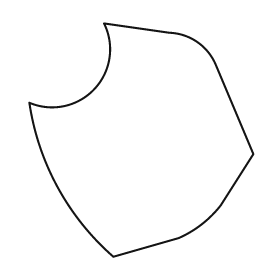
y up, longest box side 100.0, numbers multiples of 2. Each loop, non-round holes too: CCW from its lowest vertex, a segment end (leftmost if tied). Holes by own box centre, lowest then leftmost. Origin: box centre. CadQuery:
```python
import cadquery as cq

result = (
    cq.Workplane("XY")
    .moveTo(-12.0, -50.0)
    .lineTo(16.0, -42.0)
    .threePointArc((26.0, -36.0), (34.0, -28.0))
    .lineTo(48.0, -6.0)
    .lineTo(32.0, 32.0)
    .threePointArc((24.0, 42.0), (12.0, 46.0))
    .lineTo(-16.0, 50.0)
    .threePointArc((-20.0, 22.0), (-48.0, 16.0))
    .threePointArc((-36.0, -20.0), (-12.0, -50.0))
    .close()
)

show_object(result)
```